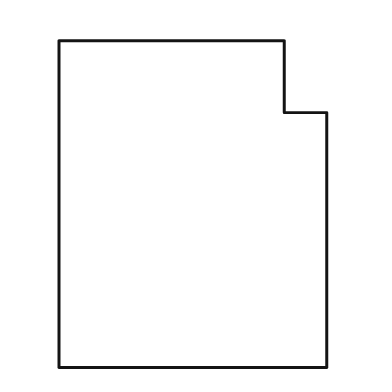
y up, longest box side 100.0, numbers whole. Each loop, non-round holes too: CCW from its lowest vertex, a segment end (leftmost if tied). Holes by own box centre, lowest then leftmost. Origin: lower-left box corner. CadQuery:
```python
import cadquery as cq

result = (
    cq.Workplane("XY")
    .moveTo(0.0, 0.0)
    .lineTo(82.0, 0.0)
    .lineTo(82.0, 78.0)
    .lineTo(69.0, 78.0)
    .lineTo(69.0, 100.0)
    .lineTo(0.0, 100.0)
    .close()
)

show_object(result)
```